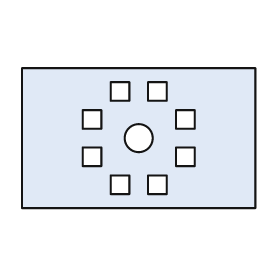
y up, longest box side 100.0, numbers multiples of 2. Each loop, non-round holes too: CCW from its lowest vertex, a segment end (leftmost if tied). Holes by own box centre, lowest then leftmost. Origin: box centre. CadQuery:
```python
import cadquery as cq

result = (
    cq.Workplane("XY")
    .moveTo(-50.0, -30.0)
    .lineTo(50.0, -30.0)
    .lineTo(50.0, 30.0)
    .lineTo(-50.0, 30.0)
    .close()
    .moveTo(-12.0, -24.0)
    .lineTo(-4.0, -24.0)
    .lineTo(-4.0, -16.0)
    .lineTo(-12.0, -16.0)
    .close()
    .moveTo(4.0, -24.0)
    .lineTo(12.0, -24.0)
    .lineTo(12.0, -16.0)
    .lineTo(4.0, -16.0)
    .close()
    .moveTo(-24.0, -12.0)
    .lineTo(-16.0, -12.0)
    .lineTo(-16.0, -4.0)
    .lineTo(-24.0, -4.0)
    .close()
    .moveTo(16.0, -12.0)
    .lineTo(24.0, -12.0)
    .lineTo(24.0, -4.0)
    .lineTo(16.0, -4.0)
    .close()
    .moveTo(0.0, 0.0)
    .circle(6.0)
    .moveTo(-24.0, 4.0)
    .lineTo(-16.0, 4.0)
    .lineTo(-16.0, 12.0)
    .lineTo(-24.0, 12.0)
    .close()
    .moveTo(16.0, 4.0)
    .lineTo(24.0, 4.0)
    .lineTo(24.0, 12.0)
    .lineTo(16.0, 12.0)
    .close()
    .moveTo(-12.0, 16.0)
    .lineTo(-4.0, 16.0)
    .lineTo(-4.0, 24.0)
    .lineTo(-12.0, 24.0)
    .close()
    .moveTo(4.0, 16.0)
    .lineTo(12.0, 16.0)
    .lineTo(12.0, 24.0)
    .lineTo(4.0, 24.0)
    .close()
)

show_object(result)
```